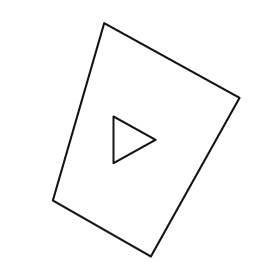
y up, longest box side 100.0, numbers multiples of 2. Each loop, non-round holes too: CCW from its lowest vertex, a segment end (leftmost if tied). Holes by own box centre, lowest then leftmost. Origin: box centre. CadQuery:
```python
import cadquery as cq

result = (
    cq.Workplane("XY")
    .moveTo(2.0, -50.0)
    .lineTo(40.0, 18.0)
    .lineTo(-18.0, 50.0)
    .lineTo(-40.0, -26.0)
    .close()
    .moveTo(-14.0, -10.0)
    .lineTo(4.0, 0.0)
    .lineTo(-14.0, 10.0)
    .close()
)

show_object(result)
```